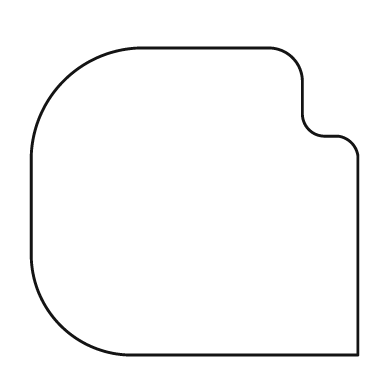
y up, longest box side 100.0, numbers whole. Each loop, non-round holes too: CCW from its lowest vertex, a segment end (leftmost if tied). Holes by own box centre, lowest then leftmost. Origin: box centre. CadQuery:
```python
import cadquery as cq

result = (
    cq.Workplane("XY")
    .moveTo(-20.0, -47.0)
    .lineTo(50.0, -47.0)
    .lineTo(50.0, 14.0)
    .threePointArc((48.0, 18.0), (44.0, 20.0))
    .lineTo(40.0, 20.0)
    .threePointArc((35.0, 22.0), (33.0, 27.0))
    .lineTo(33.0, 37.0)
    .threePointArc((30.0, 44.0), (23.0, 47.0))
    .lineTo(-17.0, 47.0)
    .threePointArc((-40.0, 37.0), (-50.0, 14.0))
    .lineTo(-50.0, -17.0)
    .threePointArc((-41.0, -38.0), (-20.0, -47.0))
    .close()
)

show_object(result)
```